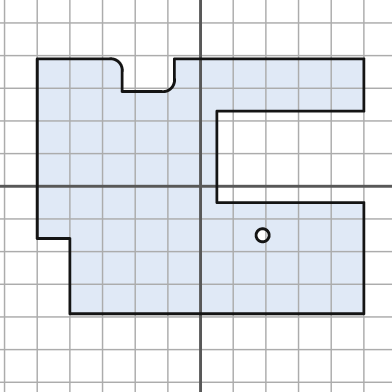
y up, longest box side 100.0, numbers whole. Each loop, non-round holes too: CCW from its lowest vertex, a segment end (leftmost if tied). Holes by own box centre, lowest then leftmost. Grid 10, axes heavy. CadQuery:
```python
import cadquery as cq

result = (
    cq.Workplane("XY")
    .moveTo(-40.0, -39.0)
    .lineTo(50.0, -39.0)
    .lineTo(50.0, -5.0)
    .lineTo(5.0, -5.0)
    .lineTo(5.0, 23.0)
    .lineTo(50.0, 23.0)
    .lineTo(50.0, 39.0)
    .lineTo(-8.0, 39.0)
    .lineTo(-8.0, 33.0)
    .threePointArc((-9.0, 30.0), (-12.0, 29.0))
    .lineTo(-24.0, 29.0)
    .lineTo(-24.0, 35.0)
    .threePointArc((-25.0, 38.0), (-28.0, 39.0))
    .lineTo(-50.0, 39.0)
    .lineTo(-50.0, -16.0)
    .lineTo(-40.0, -16.0)
    .close()
    .moveTo(19.0, -15.0)
    .circle(2.0)
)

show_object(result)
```